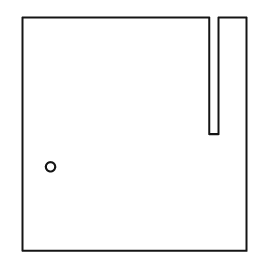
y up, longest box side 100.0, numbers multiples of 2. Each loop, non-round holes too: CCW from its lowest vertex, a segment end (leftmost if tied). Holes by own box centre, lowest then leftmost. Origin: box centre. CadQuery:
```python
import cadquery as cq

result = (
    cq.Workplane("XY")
    .moveTo(-48.0, -50.0)
    .lineTo(48.0, -50.0)
    .lineTo(48.0, 50.0)
    .lineTo(36.0, 50.0)
    .lineTo(36.0, 0.0)
    .lineTo(32.0, 0.0)
    .lineTo(32.0, 50.0)
    .lineTo(-48.0, 50.0)
    .close()
    .moveTo(-36.0, -14.0)
    .circle(2.0)
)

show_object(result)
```